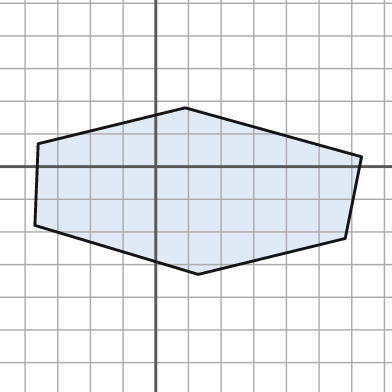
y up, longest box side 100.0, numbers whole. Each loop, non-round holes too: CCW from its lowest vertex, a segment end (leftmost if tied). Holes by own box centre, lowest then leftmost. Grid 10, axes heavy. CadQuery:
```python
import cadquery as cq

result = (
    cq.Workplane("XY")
    .moveTo(13.0, -33.0)
    .lineTo(58.0, -22.0)
    .lineTo(63.0, 3.0)
    .lineTo(9.0, 18.0)
    .lineTo(-36.0, 7.0)
    .lineTo(-37.0, -18.0)
    .close()
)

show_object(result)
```